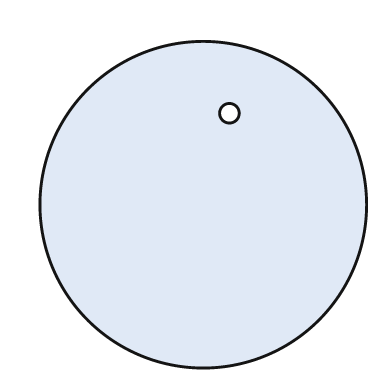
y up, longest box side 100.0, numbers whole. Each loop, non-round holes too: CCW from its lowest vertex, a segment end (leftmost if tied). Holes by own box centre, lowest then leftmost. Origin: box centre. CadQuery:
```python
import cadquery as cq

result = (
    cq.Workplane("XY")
    .moveTo(0.0, 0.0)
    .circle(50.0)
    .moveTo(8.0, 28.0)
    .circle(3.0)
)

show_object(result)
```